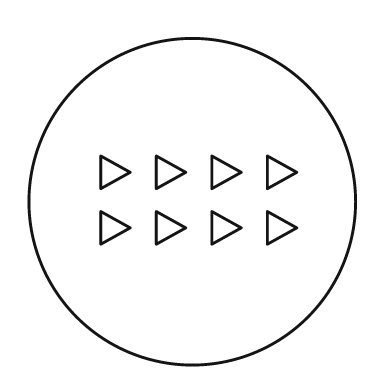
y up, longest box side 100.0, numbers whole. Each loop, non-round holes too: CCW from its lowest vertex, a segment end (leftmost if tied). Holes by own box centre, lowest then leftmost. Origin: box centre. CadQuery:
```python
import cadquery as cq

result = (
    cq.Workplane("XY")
    .moveTo(0.0, 0.0)
    .circle(50.0)
    .moveTo(-28.0, -13.0)
    .lineTo(-19.0, -8.0)
    .lineTo(-28.0, -3.0)
    .close()
    .moveTo(-11.0, -13.0)
    .lineTo(-2.0, -8.0)
    .lineTo(-11.0, -3.0)
    .close()
    .moveTo(6.0, -13.0)
    .lineTo(15.0, -8.0)
    .lineTo(6.0, -3.0)
    .close()
    .moveTo(23.0, -13.0)
    .lineTo(32.0, -8.0)
    .lineTo(23.0, -3.0)
    .close()
    .moveTo(-28.0, 4.0)
    .lineTo(-19.0, 9.0)
    .lineTo(-28.0, 14.0)
    .close()
    .moveTo(-11.0, 4.0)
    .lineTo(-2.0, 9.0)
    .lineTo(-11.0, 14.0)
    .close()
    .moveTo(6.0, 4.0)
    .lineTo(15.0, 9.0)
    .lineTo(6.0, 14.0)
    .close()
    .moveTo(23.0, 4.0)
    .lineTo(32.0, 9.0)
    .lineTo(23.0, 14.0)
    .close()
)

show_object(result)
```